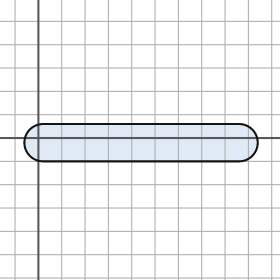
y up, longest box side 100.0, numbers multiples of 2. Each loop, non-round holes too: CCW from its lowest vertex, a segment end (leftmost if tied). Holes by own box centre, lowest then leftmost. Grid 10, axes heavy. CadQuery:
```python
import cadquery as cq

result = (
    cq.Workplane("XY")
    .moveTo(2.0, -10.0)
    .lineTo(86.0, -10.0)
    .threePointArc((94.0, -2.0), (86.0, 6.0))
    .lineTo(2.0, 6.0)
    .threePointArc((-6.0, -2.0), (2.0, -10.0))
    .close()
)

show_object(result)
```